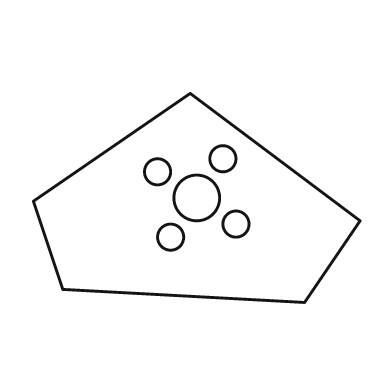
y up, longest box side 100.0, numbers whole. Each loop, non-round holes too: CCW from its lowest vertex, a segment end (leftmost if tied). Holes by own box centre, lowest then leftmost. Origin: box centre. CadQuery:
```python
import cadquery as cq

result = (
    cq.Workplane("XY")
    .moveTo(33.0, -32.0)
    .lineTo(50.0, -7.0)
    .lineTo(-2.0, 32.0)
    .lineTo(-50.0, -1.0)
    .lineTo(-41.0, -28.0)
    .close()
    .moveTo(-8.0, -12.0)
    .circle(4.0)
    .moveTo(12.0, -8.0)
    .circle(4.0)
    .moveTo(0.0, 0.0)
    .circle(7.0)
    .moveTo(-12.0, 8.0)
    .circle(4.0)
    .moveTo(8.0, 12.0)
    .circle(4.0)
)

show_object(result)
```